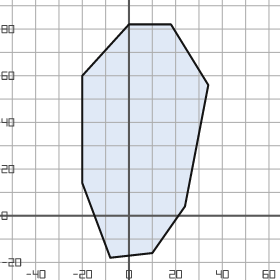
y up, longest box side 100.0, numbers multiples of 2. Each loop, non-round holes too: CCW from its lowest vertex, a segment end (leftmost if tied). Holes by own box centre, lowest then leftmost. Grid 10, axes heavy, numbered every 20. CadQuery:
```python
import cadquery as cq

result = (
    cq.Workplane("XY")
    .moveTo(-8.0, -18.0)
    .lineTo(10.0, -16.0)
    .lineTo(24.0, 4.0)
    .lineTo(34.0, 56.0)
    .lineTo(18.0, 82.0)
    .lineTo(0.0, 82.0)
    .lineTo(-20.0, 60.0)
    .lineTo(-20.0, 14.0)
    .close()
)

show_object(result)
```